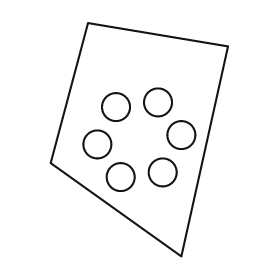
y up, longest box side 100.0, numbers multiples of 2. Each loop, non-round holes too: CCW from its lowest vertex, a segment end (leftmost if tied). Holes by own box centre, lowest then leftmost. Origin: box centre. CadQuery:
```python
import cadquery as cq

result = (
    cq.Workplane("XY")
    .moveTo(18.0, -50.0)
    .lineTo(38.0, 40.0)
    .lineTo(-22.0, 50.0)
    .lineTo(-38.0, -10.0)
    .close()
    .moveTo(-8.0, -16.0)
    .circle(6.0)
    .moveTo(10.0, -14.0)
    .circle(6.0)
    .moveTo(-18.0, -2.0)
    .circle(6.0)
    .moveTo(18.0, 2.0)
    .circle(6.0)
    .moveTo(-10.0, 14.0)
    .circle(6.0)
    .moveTo(8.0, 16.0)
    .circle(6.0)
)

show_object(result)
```